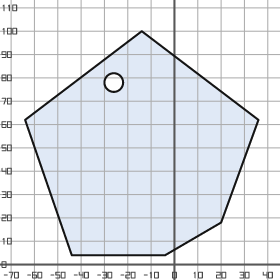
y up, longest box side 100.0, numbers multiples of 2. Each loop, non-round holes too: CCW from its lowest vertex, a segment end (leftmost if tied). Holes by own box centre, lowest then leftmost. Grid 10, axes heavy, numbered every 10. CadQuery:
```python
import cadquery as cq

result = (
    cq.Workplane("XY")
    .moveTo(-44.0, 4.0)
    .lineTo(-4.0, 4.0)
    .lineTo(20.0, 18.0)
    .lineTo(36.0, 62.0)
    .lineTo(-14.0, 100.0)
    .lineTo(-64.0, 62.0)
    .close()
    .moveTo(-26.0, 78.0)
    .circle(4.0)
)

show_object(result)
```